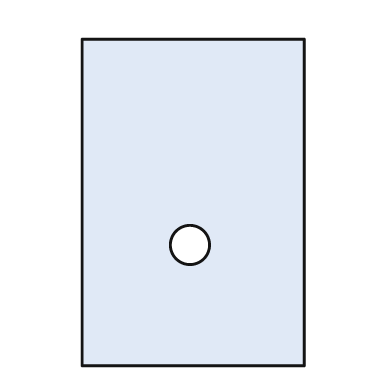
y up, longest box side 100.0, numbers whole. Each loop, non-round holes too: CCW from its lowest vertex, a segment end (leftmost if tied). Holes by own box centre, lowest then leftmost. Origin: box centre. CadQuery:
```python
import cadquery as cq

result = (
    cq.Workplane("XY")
    .moveTo(-34.0, -50.0)
    .lineTo(34.0, -50.0)
    .lineTo(34.0, 50.0)
    .lineTo(-34.0, 50.0)
    .close()
    .moveTo(-1.0, -13.0)
    .circle(6.0)
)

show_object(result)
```